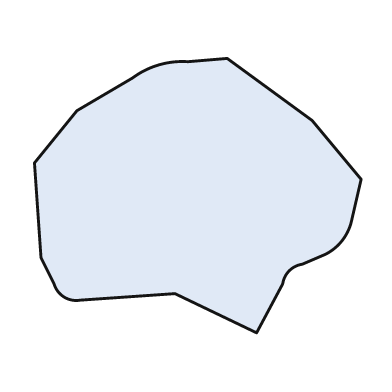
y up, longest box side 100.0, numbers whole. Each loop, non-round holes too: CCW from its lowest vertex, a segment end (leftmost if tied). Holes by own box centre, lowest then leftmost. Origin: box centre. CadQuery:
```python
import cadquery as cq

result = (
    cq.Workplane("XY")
    .moveTo(18.0, -42.0)
    .lineTo(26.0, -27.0)
    .threePointArc((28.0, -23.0), (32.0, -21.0))
    .lineTo(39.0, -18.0)
    .threePointArc((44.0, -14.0), (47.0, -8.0))
    .lineTo(50.0, 5.0)
    .lineTo(35.0, 23.0)
    .lineTo(9.0, 42.0)
    .lineTo(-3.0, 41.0)
    .threePointArc((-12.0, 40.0), (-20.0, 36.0))
    .lineTo(-37.0, 26.0)
    .lineTo(-50.0, 10.0)
    .lineTo(-48.0, -19.0)
    .lineTo(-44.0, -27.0)
    .threePointArc((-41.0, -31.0), (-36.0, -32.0))
    .lineTo(-7.0, -30.0)
    .close()
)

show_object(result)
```